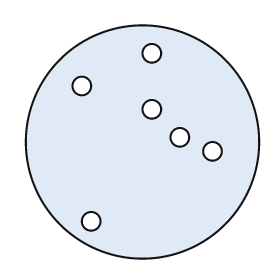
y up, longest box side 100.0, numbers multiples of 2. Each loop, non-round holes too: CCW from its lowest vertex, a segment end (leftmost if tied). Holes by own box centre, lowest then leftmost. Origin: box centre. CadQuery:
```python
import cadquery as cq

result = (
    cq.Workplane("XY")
    .moveTo(0.0, 0.0)
    .circle(50.0)
    .moveTo(-22.0, -34.0)
    .circle(4.0)
    .moveTo(30.0, -4.0)
    .circle(4.0)
    .moveTo(16.0, 2.0)
    .circle(4.0)
    .moveTo(4.0, 14.0)
    .circle(4.0)
    .moveTo(-26.0, 24.0)
    .circle(4.0)
    .moveTo(4.0, 38.0)
    .circle(4.0)
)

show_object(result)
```